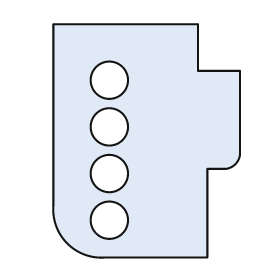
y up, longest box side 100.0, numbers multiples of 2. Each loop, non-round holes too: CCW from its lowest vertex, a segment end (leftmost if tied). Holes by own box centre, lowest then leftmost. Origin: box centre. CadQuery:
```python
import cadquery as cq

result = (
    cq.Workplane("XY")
    .moveTo(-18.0, -50.0)
    .lineTo(26.0, -50.0)
    .lineTo(26.0, -12.0)
    .lineTo(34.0, -12.0)
    .threePointArc((38.0, -10.0), (40.0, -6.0))
    .lineTo(40.0, 30.0)
    .lineTo(22.0, 30.0)
    .lineTo(22.0, 50.0)
    .lineTo(-40.0, 50.0)
    .lineTo(-40.0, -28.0)
    .threePointArc((-34.0, -44.0), (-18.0, -50.0))
    .close()
    .moveTo(-16.0, -34.0)
    .circle(8.0)
    .moveTo(-16.0, -14.0)
    .circle(8.0)
    .moveTo(-16.0, 6.0)
    .circle(8.0)
    .moveTo(-16.0, 26.0)
    .circle(8.0)
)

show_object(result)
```